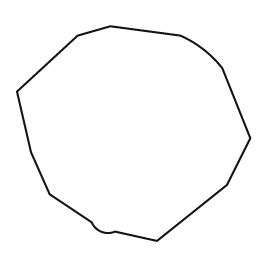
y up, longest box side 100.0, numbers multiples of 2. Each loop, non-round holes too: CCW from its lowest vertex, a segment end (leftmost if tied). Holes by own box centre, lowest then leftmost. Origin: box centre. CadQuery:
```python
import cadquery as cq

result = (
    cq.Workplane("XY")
    .moveTo(10.0, -46.0)
    .lineTo(40.0, -22.0)
    .lineTo(50.0, -2.0)
    .lineTo(38.0, 28.0)
    .threePointArc((30.0, 36.0), (20.0, 42.0))
    .lineTo(-10.0, 46.0)
    .lineTo(-24.0, 42.0)
    .lineTo(-50.0, 18.0)
    .lineTo(-44.0, -8.0)
    .lineTo(-36.0, -26.0)
    .lineTo(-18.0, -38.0)
    .threePointArc((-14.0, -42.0), (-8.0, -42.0))
    .close()
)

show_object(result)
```